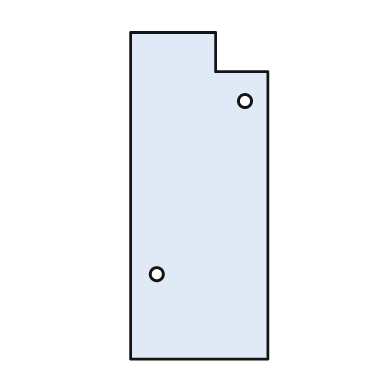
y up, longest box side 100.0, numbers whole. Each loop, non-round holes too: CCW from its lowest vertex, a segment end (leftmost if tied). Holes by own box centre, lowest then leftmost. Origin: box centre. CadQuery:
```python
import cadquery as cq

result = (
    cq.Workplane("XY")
    .moveTo(-21.0, -50.0)
    .lineTo(21.0, -50.0)
    .lineTo(21.0, 38.0)
    .lineTo(5.0, 38.0)
    .lineTo(5.0, 50.0)
    .lineTo(-21.0, 50.0)
    .close()
    .moveTo(-13.0, -24.0)
    .circle(2.0)
    .moveTo(14.0, 29.0)
    .circle(2.0)
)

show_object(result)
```